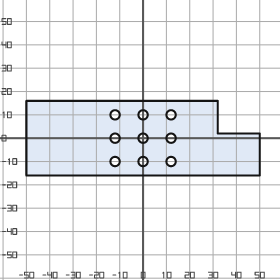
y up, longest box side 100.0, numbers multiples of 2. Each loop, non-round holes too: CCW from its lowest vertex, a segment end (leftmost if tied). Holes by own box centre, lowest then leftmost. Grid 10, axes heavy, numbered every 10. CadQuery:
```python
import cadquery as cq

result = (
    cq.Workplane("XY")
    .moveTo(-50.0, -16.0)
    .lineTo(50.0, -16.0)
    .lineTo(50.0, 2.0)
    .lineTo(32.0, 2.0)
    .lineTo(32.0, 16.0)
    .lineTo(-50.0, 16.0)
    .close()
    .moveTo(-12.0, -10.0)
    .circle(2.0)
    .moveTo(0.0, -10.0)
    .circle(2.0)
    .moveTo(12.0, -10.0)
    .circle(2.0)
    .moveTo(-12.0, 0.0)
    .circle(2.0)
    .moveTo(0.0, 0.0)
    .circle(2.0)
    .moveTo(12.0, 0.0)
    .circle(2.0)
    .moveTo(-12.0, 10.0)
    .circle(2.0)
    .moveTo(0.0, 10.0)
    .circle(2.0)
    .moveTo(12.0, 10.0)
    .circle(2.0)
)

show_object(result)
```